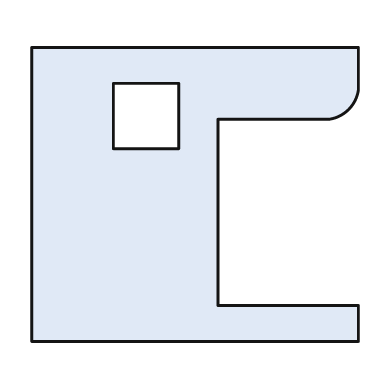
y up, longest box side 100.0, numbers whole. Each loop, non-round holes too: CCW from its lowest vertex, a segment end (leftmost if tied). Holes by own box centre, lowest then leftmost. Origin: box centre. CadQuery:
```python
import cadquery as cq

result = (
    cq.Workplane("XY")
    .moveTo(-50.0, -45.0)
    .lineTo(50.0, -45.0)
    .lineTo(50.0, -34.0)
    .lineTo(7.0, -34.0)
    .lineTo(7.0, 23.0)
    .lineTo(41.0, 23.0)
    .threePointArc((47.0, 26.0), (50.0, 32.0))
    .lineTo(50.0, 45.0)
    .lineTo(-50.0, 45.0)
    .close()
    .moveTo(-25.0, 14.0)
    .lineTo(-5.0, 14.0)
    .lineTo(-5.0, 34.0)
    .lineTo(-25.0, 34.0)
    .close()
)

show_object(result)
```